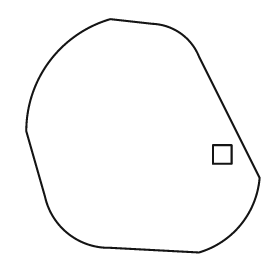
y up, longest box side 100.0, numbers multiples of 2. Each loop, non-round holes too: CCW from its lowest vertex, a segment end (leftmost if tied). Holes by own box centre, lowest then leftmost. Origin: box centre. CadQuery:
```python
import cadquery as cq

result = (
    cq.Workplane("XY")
    .moveTo(24.0, -50.0)
    .threePointArc((42.0, -38.0), (50.0, -18.0))
    .lineTo(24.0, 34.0)
    .threePointArc((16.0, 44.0), (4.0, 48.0))
    .lineTo(-14.0, 50.0)
    .threePointArc((-40.0, 32.0), (-50.0, 2.0))
    .lineTo(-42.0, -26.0)
    .threePointArc((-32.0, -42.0), (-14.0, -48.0))
    .close()
    .moveTo(30.0, -12.0)
    .lineTo(38.0, -12.0)
    .lineTo(38.0, -4.0)
    .lineTo(30.0, -4.0)
    .close()
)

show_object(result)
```